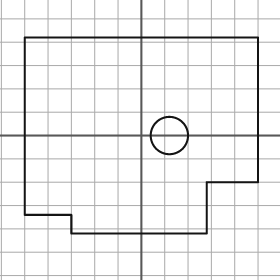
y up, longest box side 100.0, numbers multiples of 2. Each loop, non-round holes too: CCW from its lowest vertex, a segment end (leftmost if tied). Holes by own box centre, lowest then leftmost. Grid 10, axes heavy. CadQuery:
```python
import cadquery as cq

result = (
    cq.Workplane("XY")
    .moveTo(-30.0, -42.0)
    .lineTo(28.0, -42.0)
    .lineTo(28.0, -20.0)
    .lineTo(50.0, -20.0)
    .lineTo(50.0, 42.0)
    .lineTo(-50.0, 42.0)
    .lineTo(-50.0, -34.0)
    .lineTo(-30.0, -34.0)
    .close()
    .moveTo(12.0, 0.0)
    .circle(8.0)
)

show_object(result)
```